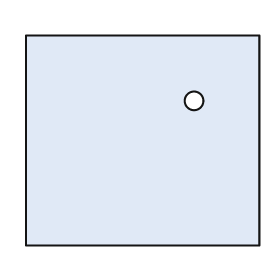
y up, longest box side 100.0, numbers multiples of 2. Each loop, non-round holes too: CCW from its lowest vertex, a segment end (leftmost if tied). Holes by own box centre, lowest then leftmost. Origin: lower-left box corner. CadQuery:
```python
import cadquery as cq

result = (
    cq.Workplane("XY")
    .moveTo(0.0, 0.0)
    .lineTo(100.0, 0.0)
    .lineTo(100.0, 90.0)
    .lineTo(0.0, 90.0)
    .close()
    .moveTo(72.0, 62.0)
    .circle(4.0)
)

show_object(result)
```